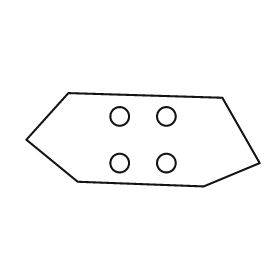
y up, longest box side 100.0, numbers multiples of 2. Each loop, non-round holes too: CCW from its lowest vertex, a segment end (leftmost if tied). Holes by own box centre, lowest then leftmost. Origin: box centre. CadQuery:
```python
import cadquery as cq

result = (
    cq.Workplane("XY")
    .moveTo(26.0, -20.0)
    .lineTo(50.0, -10.0)
    .lineTo(34.0, 18.0)
    .lineTo(-32.0, 20.0)
    .lineTo(-50.0, 0.0)
    .lineTo(-28.0, -18.0)
    .close()
    .moveTo(-10.0, -10.0)
    .circle(4.0)
    .moveTo(10.0, -10.0)
    .circle(4.0)
    .moveTo(-10.0, 10.0)
    .circle(4.0)
    .moveTo(10.0, 10.0)
    .circle(4.0)
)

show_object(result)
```